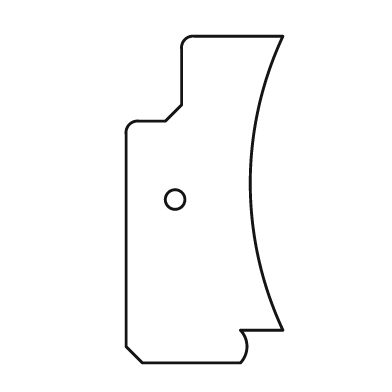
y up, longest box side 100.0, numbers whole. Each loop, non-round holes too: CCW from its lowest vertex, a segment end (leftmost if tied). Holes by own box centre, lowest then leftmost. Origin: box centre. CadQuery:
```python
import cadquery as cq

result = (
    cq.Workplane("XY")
    .moveTo(-19.0, -50.0)
    .lineTo(11.0, -50.0)
    .threePointArc((13.0, -45.0), (11.0, -40.0))
    .lineTo(24.0, -40.0)
    .threePointArc((14.0, 5.0), (24.0, 50.0))
    .lineTo(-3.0, 50.0)
    .threePointArc((-6.0, 49.0), (-7.0, 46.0))
    .lineTo(-7.0, 29.0)
    .lineTo(-12.0, 24.0)
    .lineTo(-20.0, 24.0)
    .threePointArc((-23.0, 23.0), (-24.0, 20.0))
    .lineTo(-24.0, -45.0)
    .close()
    .moveTo(-9.0, 0.0)
    .circle(3.0)
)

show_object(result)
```